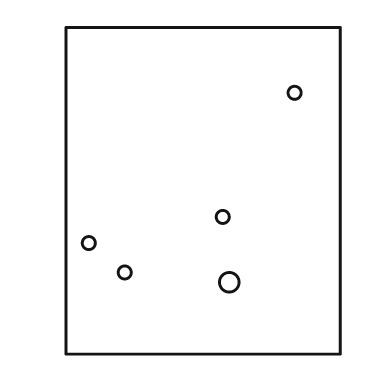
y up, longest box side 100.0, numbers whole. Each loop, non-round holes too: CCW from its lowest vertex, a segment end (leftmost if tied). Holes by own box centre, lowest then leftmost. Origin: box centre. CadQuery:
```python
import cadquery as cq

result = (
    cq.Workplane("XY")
    .moveTo(-42.0, -50.0)
    .lineTo(42.0, -50.0)
    .lineTo(42.0, 50.0)
    .lineTo(-42.0, 50.0)
    .close()
    .moveTo(8.0, -28.0)
    .circle(3.0)
    .moveTo(-24.0, -25.0)
    .circle(2.0)
    .moveTo(-35.0, -16.0)
    .circle(2.0)
    .moveTo(6.0, -8.0)
    .circle(2.0)
    .moveTo(28.0, 30.0)
    .circle(2.0)
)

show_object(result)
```